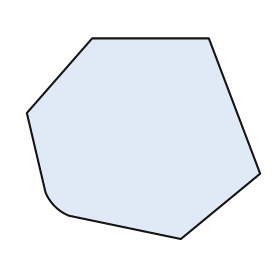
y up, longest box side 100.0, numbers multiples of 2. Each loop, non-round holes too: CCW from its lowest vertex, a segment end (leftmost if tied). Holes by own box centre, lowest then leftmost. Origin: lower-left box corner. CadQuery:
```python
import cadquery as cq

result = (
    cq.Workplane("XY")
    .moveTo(66.0, 0.0)
    .lineTo(100.0, 28.0)
    .lineTo(78.0, 86.0)
    .lineTo(28.0, 86.0)
    .lineTo(0.0, 54.0)
    .lineTo(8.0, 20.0)
    .threePointArc((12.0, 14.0), (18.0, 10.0))
    .close()
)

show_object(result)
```